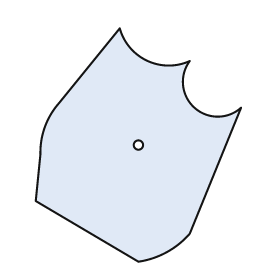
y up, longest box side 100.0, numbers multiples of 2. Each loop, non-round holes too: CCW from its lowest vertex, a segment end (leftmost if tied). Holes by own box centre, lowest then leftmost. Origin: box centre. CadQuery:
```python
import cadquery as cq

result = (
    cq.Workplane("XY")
    .moveTo(0.0, -50.0)
    .threePointArc((12.0, -46.0), (22.0, -38.0))
    .lineTo(44.0, 16.0)
    .threePointArc((24.0, 16.0), (22.0, 36.0))
    .threePointArc((4.0, 36.0), (-8.0, 50.0))
    .lineTo(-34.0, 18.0)
    .threePointArc((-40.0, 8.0), (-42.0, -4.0))
    .lineTo(-44.0, -24.0)
    .close()
    .moveTo(0.0, 0.0)
    .circle(2.0)
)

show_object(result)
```